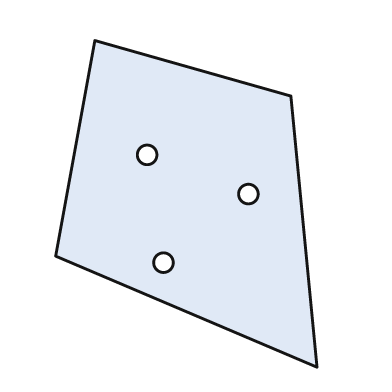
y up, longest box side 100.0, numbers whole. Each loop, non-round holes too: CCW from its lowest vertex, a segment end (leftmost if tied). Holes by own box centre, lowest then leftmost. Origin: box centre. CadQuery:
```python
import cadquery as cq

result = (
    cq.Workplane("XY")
    .moveTo(40.0, -50.0)
    .lineTo(32.0, 33.0)
    .lineTo(-28.0, 50.0)
    .lineTo(-40.0, -16.0)
    .close()
    .moveTo(-7.0, -18.0)
    .circle(3.0)
    .moveTo(19.0, 3.0)
    .circle(3.0)
    .moveTo(-12.0, 15.0)
    .circle(3.0)
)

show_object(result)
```